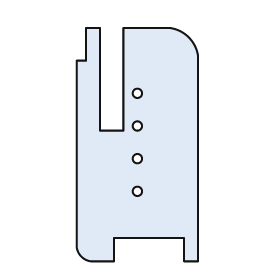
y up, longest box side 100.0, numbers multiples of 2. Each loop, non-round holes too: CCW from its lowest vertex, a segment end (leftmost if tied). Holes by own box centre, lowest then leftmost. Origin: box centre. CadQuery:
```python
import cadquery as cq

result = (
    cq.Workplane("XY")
    .moveTo(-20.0, -50.0)
    .lineTo(-10.0, -50.0)
    .lineTo(-10.0, -40.0)
    .lineTo(20.0, -40.0)
    .lineTo(20.0, -50.0)
    .lineTo(26.0, -50.0)
    .lineTo(26.0, 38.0)
    .threePointArc((22.0, 46.0), (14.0, 50.0))
    .lineTo(-6.0, 50.0)
    .lineTo(-6.0, 6.0)
    .lineTo(-16.0, 6.0)
    .lineTo(-16.0, 50.0)
    .lineTo(-22.0, 50.0)
    .lineTo(-22.0, 36.0)
    .lineTo(-26.0, 36.0)
    .lineTo(-26.0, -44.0)
    .threePointArc((-24.0, -48.0), (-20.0, -50.0))
    .close()
    .moveTo(0.0, -20.0)
    .circle(2.0)
    .moveTo(0.0, -6.0)
    .circle(2.0)
    .moveTo(0.0, 8.0)
    .circle(2.0)
    .moveTo(0.0, 22.0)
    .circle(2.0)
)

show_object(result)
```